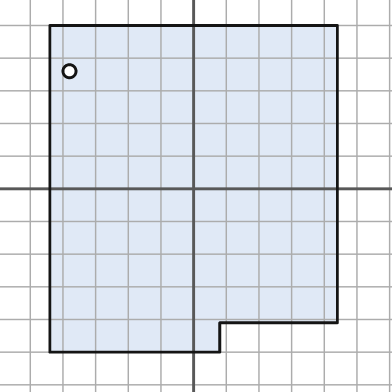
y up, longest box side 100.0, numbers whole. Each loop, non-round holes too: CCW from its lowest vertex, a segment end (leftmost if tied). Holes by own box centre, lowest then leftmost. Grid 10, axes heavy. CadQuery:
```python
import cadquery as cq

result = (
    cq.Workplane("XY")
    .moveTo(-44.0, -50.0)
    .lineTo(8.0, -50.0)
    .lineTo(8.0, -41.0)
    .lineTo(44.0, -41.0)
    .lineTo(44.0, 50.0)
    .lineTo(-44.0, 50.0)
    .close()
    .moveTo(-38.0, 36.0)
    .circle(2.0)
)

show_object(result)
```